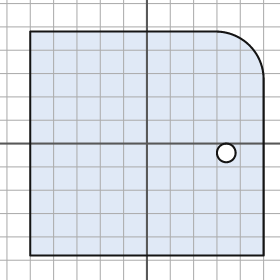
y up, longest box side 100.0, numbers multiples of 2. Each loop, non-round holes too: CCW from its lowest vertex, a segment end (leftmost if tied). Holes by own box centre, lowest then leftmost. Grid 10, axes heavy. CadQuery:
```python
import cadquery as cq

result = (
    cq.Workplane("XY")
    .moveTo(-50.0, -48.0)
    .lineTo(50.0, -48.0)
    .lineTo(50.0, 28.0)
    .threePointArc((44.0, 42.0), (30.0, 48.0))
    .lineTo(-50.0, 48.0)
    .close()
    .moveTo(34.0, -4.0)
    .circle(4.0)
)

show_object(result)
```